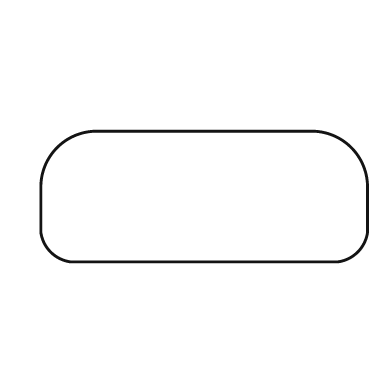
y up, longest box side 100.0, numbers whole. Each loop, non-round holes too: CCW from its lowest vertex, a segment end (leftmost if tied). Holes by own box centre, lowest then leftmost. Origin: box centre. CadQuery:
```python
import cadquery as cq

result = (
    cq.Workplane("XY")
    .moveTo(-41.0, -20.0)
    .lineTo(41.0, -20.0)
    .threePointArc((47.0, -17.0), (50.0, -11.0))
    .lineTo(50.0, 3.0)
    .threePointArc((45.0, 15.0), (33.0, 20.0))
    .lineTo(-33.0, 20.0)
    .threePointArc((-45.0, 15.0), (-50.0, 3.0))
    .lineTo(-50.0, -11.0)
    .threePointArc((-47.0, -17.0), (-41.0, -20.0))
    .close()
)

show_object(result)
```